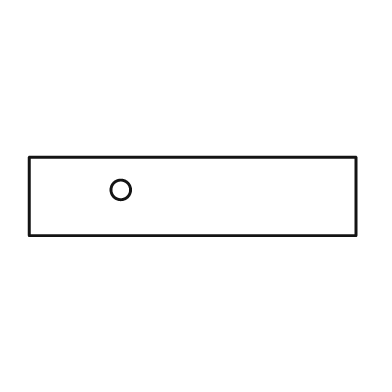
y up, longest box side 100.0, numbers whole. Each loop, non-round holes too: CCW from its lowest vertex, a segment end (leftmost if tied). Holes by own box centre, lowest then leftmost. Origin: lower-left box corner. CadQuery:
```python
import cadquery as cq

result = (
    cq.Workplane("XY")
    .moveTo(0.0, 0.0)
    .lineTo(100.0, 0.0)
    .lineTo(100.0, 24.0)
    .lineTo(0.0, 24.0)
    .close()
    .moveTo(28.0, 14.0)
    .circle(3.0)
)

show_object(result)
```